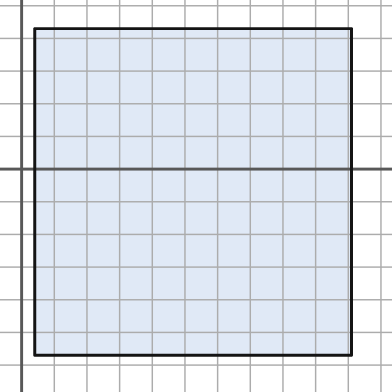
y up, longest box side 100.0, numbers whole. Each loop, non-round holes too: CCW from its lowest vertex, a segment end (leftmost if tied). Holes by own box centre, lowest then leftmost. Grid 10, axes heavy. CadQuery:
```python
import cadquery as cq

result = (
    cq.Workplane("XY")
    .moveTo(4.0, -57.0)
    .lineTo(101.0, -57.0)
    .lineTo(101.0, 43.0)
    .lineTo(4.0, 43.0)
    .close()
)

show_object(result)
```